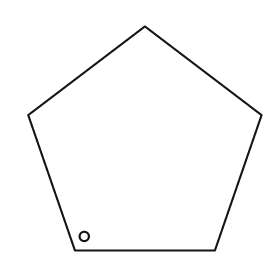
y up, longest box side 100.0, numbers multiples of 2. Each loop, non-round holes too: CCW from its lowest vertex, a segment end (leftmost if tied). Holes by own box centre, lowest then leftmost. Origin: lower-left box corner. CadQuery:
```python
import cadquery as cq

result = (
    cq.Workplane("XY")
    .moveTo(20.0, 0.0)
    .lineTo(80.0, 0.0)
    .lineTo(100.0, 58.0)
    .lineTo(50.0, 96.0)
    .lineTo(0.0, 58.0)
    .close()
    .moveTo(24.0, 6.0)
    .circle(2.0)
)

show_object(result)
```